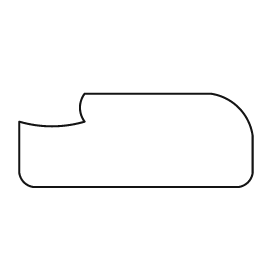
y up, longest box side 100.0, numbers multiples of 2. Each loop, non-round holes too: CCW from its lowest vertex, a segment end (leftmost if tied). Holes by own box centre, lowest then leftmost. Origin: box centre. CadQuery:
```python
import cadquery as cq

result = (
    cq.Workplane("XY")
    .moveTo(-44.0, -20.0)
    .lineTo(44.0, -20.0)
    .threePointArc((48.0, -18.0), (50.0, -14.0))
    .lineTo(50.0, 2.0)
    .threePointArc((44.0, 14.0), (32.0, 20.0))
    .lineTo(-22.0, 20.0)
    .threePointArc((-24.0, 14.0), (-22.0, 8.0))
    .threePointArc((-36.0, 6.0), (-50.0, 8.0))
    .lineTo(-50.0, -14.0)
    .threePointArc((-48.0, -18.0), (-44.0, -20.0))
    .close()
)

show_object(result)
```